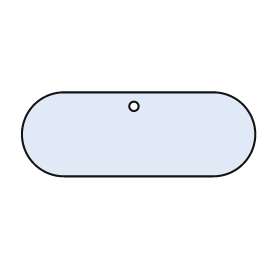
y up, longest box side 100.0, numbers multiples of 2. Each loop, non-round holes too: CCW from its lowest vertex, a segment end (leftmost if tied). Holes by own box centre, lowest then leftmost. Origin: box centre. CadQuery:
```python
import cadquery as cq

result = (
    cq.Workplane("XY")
    .moveTo(-32.0, -18.0)
    .lineTo(32.0, -18.0)
    .threePointArc((50.0, 0.0), (32.0, 18.0))
    .lineTo(-32.0, 18.0)
    .threePointArc((-50.0, 0.0), (-32.0, -18.0))
    .close()
    .moveTo(-2.0, 12.0)
    .circle(2.0)
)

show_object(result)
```